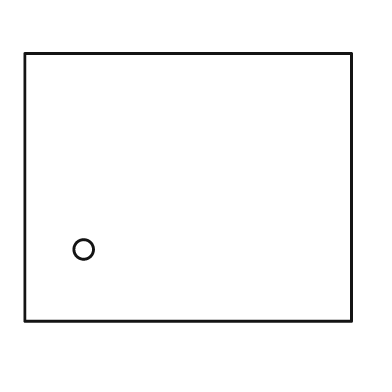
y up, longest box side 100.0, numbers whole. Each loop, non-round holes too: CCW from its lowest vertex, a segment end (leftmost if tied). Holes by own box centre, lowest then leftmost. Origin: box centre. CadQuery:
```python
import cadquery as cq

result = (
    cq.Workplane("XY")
    .moveTo(-50.0, -41.0)
    .lineTo(50.0, -41.0)
    .lineTo(50.0, 41.0)
    .lineTo(-50.0, 41.0)
    .close()
    .moveTo(-32.0, -19.0)
    .circle(3.0)
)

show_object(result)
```